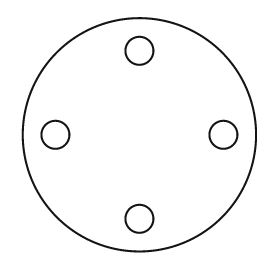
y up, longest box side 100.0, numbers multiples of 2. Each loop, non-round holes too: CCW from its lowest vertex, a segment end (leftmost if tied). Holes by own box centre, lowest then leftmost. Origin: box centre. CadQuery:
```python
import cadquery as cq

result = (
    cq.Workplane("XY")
    .moveTo(0.0, 0.0)
    .circle(50.0)
    .moveTo(0.0, -36.0)
    .circle(6.0)
    .moveTo(-36.0, 0.0)
    .circle(6.0)
    .moveTo(36.0, 0.0)
    .circle(6.0)
    .moveTo(0.0, 36.0)
    .circle(6.0)
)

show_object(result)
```